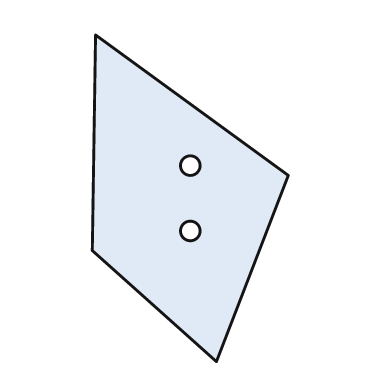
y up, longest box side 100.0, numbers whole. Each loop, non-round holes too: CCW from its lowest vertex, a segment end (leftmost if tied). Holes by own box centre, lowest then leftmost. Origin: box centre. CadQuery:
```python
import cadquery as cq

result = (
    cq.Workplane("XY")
    .moveTo(8.0, -50.0)
    .lineTo(30.0, 7.0)
    .lineTo(-29.0, 50.0)
    .lineTo(-30.0, -16.0)
    .close()
    .moveTo(0.0, -10.0)
    .circle(3.0)
    .moveTo(0.0, 10.0)
    .circle(3.0)
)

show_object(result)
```